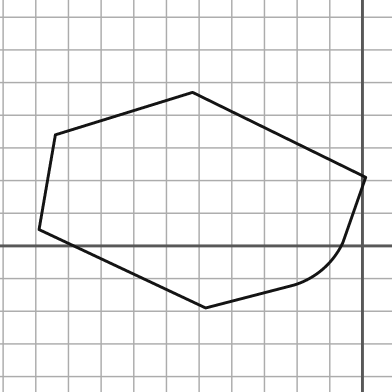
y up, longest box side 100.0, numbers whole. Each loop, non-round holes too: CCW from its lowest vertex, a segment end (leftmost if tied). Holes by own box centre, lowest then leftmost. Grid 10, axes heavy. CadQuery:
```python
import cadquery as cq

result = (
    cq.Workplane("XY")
    .moveTo(-48.0, -19.0)
    .lineTo(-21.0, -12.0)
    .threePointArc((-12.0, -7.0), (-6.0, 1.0))
    .lineTo(1.0, 21.0)
    .lineTo(-52.0, 47.0)
    .lineTo(-94.0, 34.0)
    .lineTo(-99.0, 5.0)
    .close()
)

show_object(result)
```